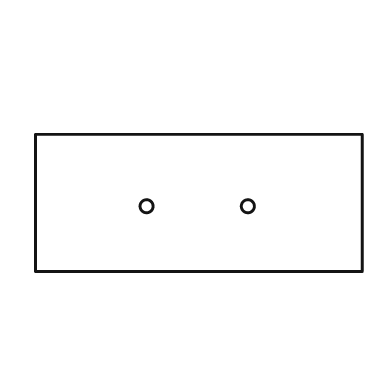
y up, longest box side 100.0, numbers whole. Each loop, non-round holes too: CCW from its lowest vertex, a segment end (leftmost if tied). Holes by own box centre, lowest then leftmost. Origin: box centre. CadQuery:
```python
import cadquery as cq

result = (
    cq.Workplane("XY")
    .moveTo(-50.0, -21.0)
    .lineTo(50.0, -21.0)
    .lineTo(50.0, 21.0)
    .lineTo(-50.0, 21.0)
    .close()
    .moveTo(-16.0, -1.0)
    .circle(2.0)
    .moveTo(15.0, -1.0)
    .circle(2.0)
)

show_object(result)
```